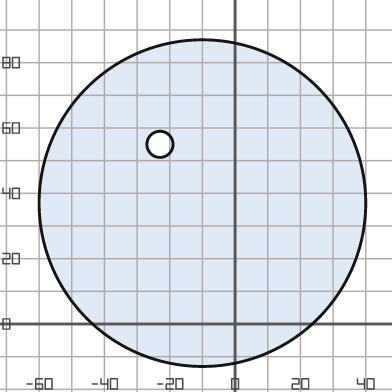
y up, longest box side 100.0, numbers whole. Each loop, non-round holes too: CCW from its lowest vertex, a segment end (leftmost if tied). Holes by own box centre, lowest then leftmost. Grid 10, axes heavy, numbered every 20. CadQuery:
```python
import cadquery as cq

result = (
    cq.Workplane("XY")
    .moveTo(-10.0, 37.0)
    .circle(50.0)
    .moveTo(-23.0, 55.0)
    .circle(4.0)
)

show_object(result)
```